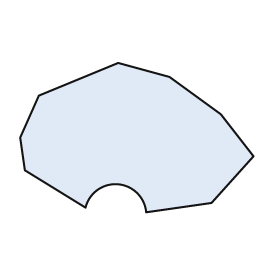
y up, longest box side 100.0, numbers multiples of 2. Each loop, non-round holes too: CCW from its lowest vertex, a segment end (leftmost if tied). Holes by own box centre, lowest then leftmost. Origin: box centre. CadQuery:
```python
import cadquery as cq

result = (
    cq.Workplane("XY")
    .moveTo(4.0, -32.0)
    .lineTo(32.0, -28.0)
    .lineTo(50.0, -8.0)
    .lineTo(36.0, 10.0)
    .lineTo(14.0, 26.0)
    .lineTo(-8.0, 32.0)
    .lineTo(-42.0, 18.0)
    .lineTo(-50.0, 0.0)
    .lineTo(-48.0, -14.0)
    .lineTo(-22.0, -30.0)
    .threePointArc((-8.0, -20.0), (4.0, -32.0))
    .close()
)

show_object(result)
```